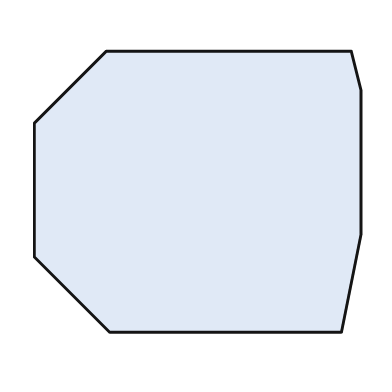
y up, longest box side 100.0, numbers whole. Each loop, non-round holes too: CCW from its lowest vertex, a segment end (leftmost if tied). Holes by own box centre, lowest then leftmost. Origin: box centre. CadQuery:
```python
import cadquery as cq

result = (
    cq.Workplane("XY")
    .moveTo(-27.0, -43.0)
    .lineTo(44.0, -43.0)
    .lineTo(50.0, -13.0)
    .lineTo(50.0, 31.0)
    .lineTo(47.0, 43.0)
    .lineTo(-28.0, 43.0)
    .lineTo(-50.0, 21.0)
    .lineTo(-50.0, -20.0)
    .close()
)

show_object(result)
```